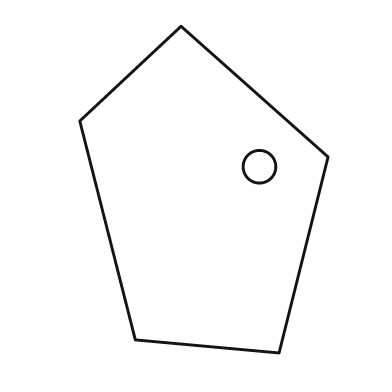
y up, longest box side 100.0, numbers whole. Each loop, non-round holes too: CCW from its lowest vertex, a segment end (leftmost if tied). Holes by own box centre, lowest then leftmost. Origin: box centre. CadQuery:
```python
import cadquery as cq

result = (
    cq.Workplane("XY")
    .moveTo(23.0, -50.0)
    .lineTo(38.0, 10.0)
    .lineTo(-7.0, 50.0)
    .lineTo(-38.0, 21.0)
    .lineTo(-21.0, -46.0)
    .close()
    .moveTo(17.0, 7.0)
    .circle(5.0)
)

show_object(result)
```